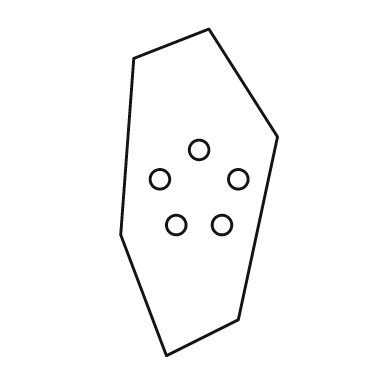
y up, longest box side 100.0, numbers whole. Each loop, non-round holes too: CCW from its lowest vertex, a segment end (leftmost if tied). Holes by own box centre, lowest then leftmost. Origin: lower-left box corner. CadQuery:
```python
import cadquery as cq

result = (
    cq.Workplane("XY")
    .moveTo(14.0, 0.0)
    .lineTo(36.0, 11.0)
    .lineTo(48.0, 67.0)
    .lineTo(27.0, 100.0)
    .lineTo(4.0, 91.0)
    .lineTo(0.0, 37.0)
    .close()
    .moveTo(17.0, 40.0)
    .circle(3.0)
    .moveTo(31.0, 40.0)
    .circle(3.0)
    .moveTo(12.0, 54.0)
    .circle(3.0)
    .moveTo(36.0, 54.0)
    .circle(3.0)
    .moveTo(24.0, 63.0)
    .circle(3.0)
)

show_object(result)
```